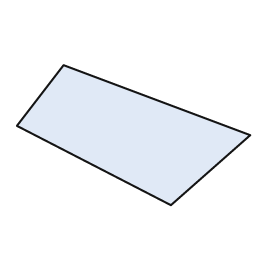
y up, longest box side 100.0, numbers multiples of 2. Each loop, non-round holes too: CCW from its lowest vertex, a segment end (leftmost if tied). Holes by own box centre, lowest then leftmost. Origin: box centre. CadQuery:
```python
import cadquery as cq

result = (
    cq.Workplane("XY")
    .moveTo(16.0, -30.0)
    .lineTo(50.0, 0.0)
    .lineTo(-30.0, 30.0)
    .lineTo(-50.0, 4.0)
    .close()
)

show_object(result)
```